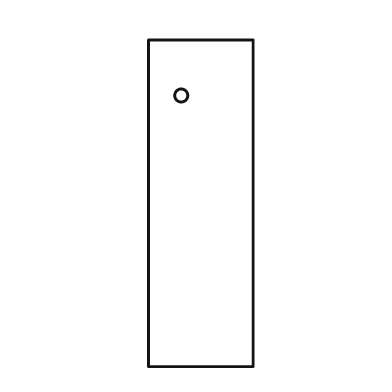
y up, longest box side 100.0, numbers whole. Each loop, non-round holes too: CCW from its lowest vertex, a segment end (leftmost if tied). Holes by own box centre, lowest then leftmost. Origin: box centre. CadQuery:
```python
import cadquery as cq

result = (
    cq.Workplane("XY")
    .moveTo(-16.0, -50.0)
    .lineTo(16.0, -50.0)
    .lineTo(16.0, 50.0)
    .lineTo(-16.0, 50.0)
    .close()
    .moveTo(-6.0, 33.0)
    .circle(2.0)
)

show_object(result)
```